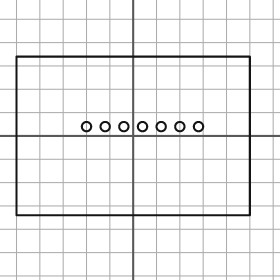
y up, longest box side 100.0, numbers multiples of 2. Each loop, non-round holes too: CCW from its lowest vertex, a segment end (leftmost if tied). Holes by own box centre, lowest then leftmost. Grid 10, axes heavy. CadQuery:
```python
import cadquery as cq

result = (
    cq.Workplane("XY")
    .moveTo(-50.0, -34.0)
    .lineTo(50.0, -34.0)
    .lineTo(50.0, 34.0)
    .lineTo(-50.0, 34.0)
    .close()
    .moveTo(-20.0, 4.0)
    .circle(2.0)
    .moveTo(-12.0, 4.0)
    .circle(2.0)
    .moveTo(-4.0, 4.0)
    .circle(2.0)
    .moveTo(4.0, 4.0)
    .circle(2.0)
    .moveTo(12.0, 4.0)
    .circle(2.0)
    .moveTo(20.0, 4.0)
    .circle(2.0)
    .moveTo(28.0, 4.0)
    .circle(2.0)
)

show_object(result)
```